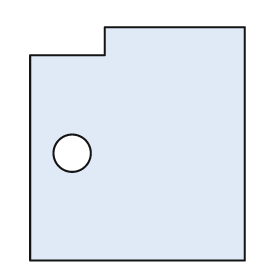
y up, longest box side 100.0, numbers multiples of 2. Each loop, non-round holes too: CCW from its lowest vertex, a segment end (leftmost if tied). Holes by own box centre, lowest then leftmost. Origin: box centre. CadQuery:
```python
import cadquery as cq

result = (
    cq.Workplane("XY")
    .moveTo(-46.0, -50.0)
    .lineTo(46.0, -50.0)
    .lineTo(46.0, 50.0)
    .lineTo(-14.0, 50.0)
    .lineTo(-14.0, 38.0)
    .lineTo(-46.0, 38.0)
    .close()
    .moveTo(-28.0, -4.0)
    .circle(8.0)
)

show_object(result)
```